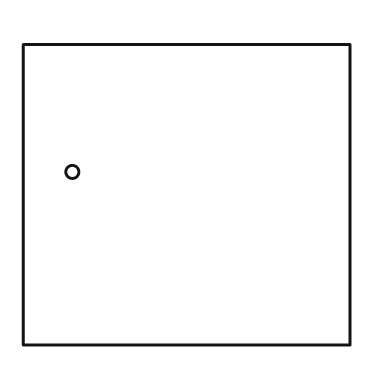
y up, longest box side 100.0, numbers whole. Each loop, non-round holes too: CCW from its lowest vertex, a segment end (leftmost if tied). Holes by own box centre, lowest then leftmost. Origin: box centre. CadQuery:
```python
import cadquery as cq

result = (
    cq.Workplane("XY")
    .moveTo(-50.0, -46.0)
    .lineTo(50.0, -46.0)
    .lineTo(50.0, 46.0)
    .lineTo(-50.0, 46.0)
    .close()
    .moveTo(-35.0, 7.0)
    .circle(2.0)
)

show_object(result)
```